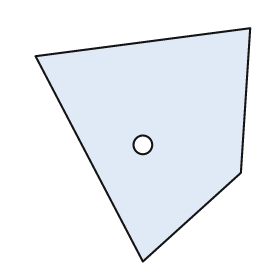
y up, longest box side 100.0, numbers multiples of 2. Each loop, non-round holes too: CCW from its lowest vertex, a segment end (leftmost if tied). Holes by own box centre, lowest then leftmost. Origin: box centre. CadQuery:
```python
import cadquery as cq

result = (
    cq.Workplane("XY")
    .moveTo(0.0, -50.0)
    .lineTo(42.0, -12.0)
    .lineTo(46.0, 50.0)
    .lineTo(-46.0, 38.0)
    .close()
    .moveTo(0.0, 0.0)
    .circle(4.0)
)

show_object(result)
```